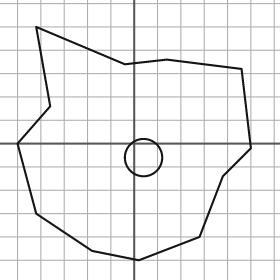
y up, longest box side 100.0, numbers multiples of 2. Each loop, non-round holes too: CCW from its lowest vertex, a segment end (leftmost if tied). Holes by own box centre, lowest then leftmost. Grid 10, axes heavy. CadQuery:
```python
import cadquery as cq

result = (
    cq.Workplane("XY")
    .moveTo(2.0, -50.0)
    .lineTo(28.0, -40.0)
    .lineTo(38.0, -14.0)
    .lineTo(50.0, -2.0)
    .lineTo(46.0, 32.0)
    .lineTo(14.0, 36.0)
    .lineTo(-4.0, 34.0)
    .lineTo(-42.0, 50.0)
    .lineTo(-36.0, 16.0)
    .lineTo(-50.0, 0.0)
    .lineTo(-42.0, -30.0)
    .lineTo(-18.0, -46.0)
    .close()
    .moveTo(4.0, -6.0)
    .circle(8.0)
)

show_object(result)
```